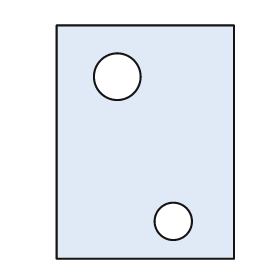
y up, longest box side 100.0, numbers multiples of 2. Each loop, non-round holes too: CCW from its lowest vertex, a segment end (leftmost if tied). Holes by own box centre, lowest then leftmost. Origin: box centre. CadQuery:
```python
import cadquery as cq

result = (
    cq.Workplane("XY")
    .moveTo(-38.0, -50.0)
    .lineTo(38.0, -50.0)
    .lineTo(38.0, 50.0)
    .lineTo(-38.0, 50.0)
    .close()
    .moveTo(12.0, -34.0)
    .circle(8.0)
    .moveTo(-12.0, 28.0)
    .circle(10.0)
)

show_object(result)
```